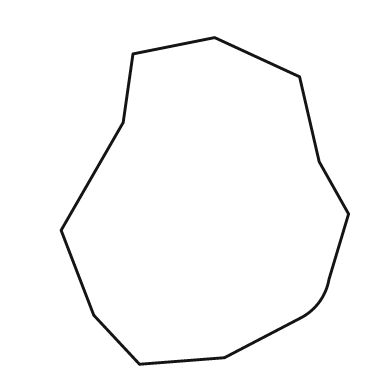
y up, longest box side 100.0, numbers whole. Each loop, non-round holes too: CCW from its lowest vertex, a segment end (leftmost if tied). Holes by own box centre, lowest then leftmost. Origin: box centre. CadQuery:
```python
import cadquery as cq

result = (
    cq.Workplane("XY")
    .moveTo(-20.0, -50.0)
    .lineTo(6.0, -48.0)
    .lineTo(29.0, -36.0)
    .threePointArc((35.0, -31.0), (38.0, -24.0))
    .lineTo(44.0, -4.0)
    .lineTo(35.0, 12.0)
    .lineTo(29.0, 38.0)
    .lineTo(3.0, 50.0)
    .lineTo(-22.0, 45.0)
    .lineTo(-25.0, 24.0)
    .lineTo(-44.0, -9.0)
    .lineTo(-34.0, -35.0)
    .close()
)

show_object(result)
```